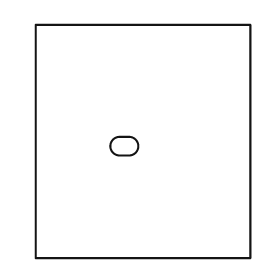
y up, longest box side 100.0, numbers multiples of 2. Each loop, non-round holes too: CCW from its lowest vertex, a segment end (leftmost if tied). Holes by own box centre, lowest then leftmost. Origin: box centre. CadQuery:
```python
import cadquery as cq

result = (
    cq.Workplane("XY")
    .moveTo(-46.0, -50.0)
    .lineTo(46.0, -50.0)
    .lineTo(46.0, 50.0)
    .lineTo(-46.0, 50.0)
    .close()
    .moveTo(-10.0, -6.0)
    .lineTo(-6.0, -6.0)
    .threePointArc((-2.0, -2.0), (-6.0, 2.0))
    .lineTo(-10.0, 2.0)
    .threePointArc((-14.0, -2.0), (-10.0, -6.0))
    .close()
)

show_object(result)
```